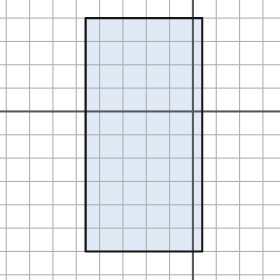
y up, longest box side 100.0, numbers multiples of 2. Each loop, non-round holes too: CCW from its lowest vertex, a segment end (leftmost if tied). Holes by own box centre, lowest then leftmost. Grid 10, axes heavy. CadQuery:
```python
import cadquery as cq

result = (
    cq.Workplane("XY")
    .moveTo(-46.0, -60.0)
    .lineTo(4.0, -60.0)
    .lineTo(4.0, 40.0)
    .lineTo(-46.0, 40.0)
    .close()
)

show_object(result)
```